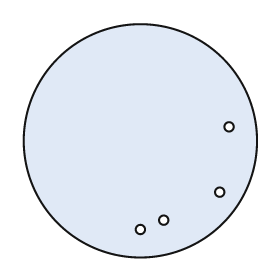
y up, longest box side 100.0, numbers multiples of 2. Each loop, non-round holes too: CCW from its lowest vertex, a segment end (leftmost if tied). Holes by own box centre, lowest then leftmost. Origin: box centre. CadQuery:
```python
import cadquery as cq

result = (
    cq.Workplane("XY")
    .moveTo(0.0, 0.0)
    .circle(50.0)
    .moveTo(0.0, -38.0)
    .circle(2.0)
    .moveTo(10.0, -34.0)
    .circle(2.0)
    .moveTo(34.0, -22.0)
    .circle(2.0)
    .moveTo(38.0, 6.0)
    .circle(2.0)
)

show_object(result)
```